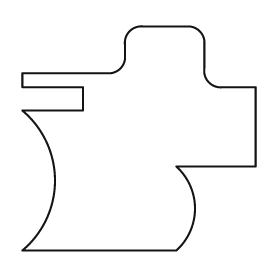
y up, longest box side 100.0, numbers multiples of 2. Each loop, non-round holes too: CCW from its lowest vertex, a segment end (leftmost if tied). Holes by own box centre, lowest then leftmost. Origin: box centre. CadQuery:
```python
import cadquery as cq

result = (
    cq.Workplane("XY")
    .moveTo(-50.0, -48.0)
    .lineTo(16.0, -48.0)
    .threePointArc((24.0, -30.0), (16.0, -12.0))
    .lineTo(50.0, -12.0)
    .lineTo(50.0, 22.0)
    .lineTo(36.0, 22.0)
    .threePointArc((30.0, 24.0), (28.0, 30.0))
    .lineTo(28.0, 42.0)
    .threePointArc((26.0, 46.0), (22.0, 48.0))
    .lineTo(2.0, 48.0)
    .threePointArc((-4.0, 46.0), (-6.0, 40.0))
    .lineTo(-6.0, 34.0)
    .threePointArc((-8.0, 30.0), (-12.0, 28.0))
    .lineTo(-50.0, 28.0)
    .lineTo(-50.0, 22.0)
    .lineTo(-24.0, 22.0)
    .lineTo(-24.0, 12.0)
    .lineTo(-50.0, 12.0)
    .threePointArc((-36.0, -18.0), (-50.0, -48.0))
    .close()
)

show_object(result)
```